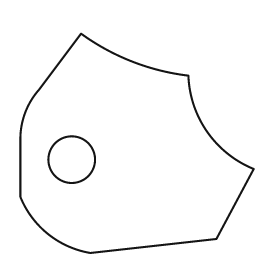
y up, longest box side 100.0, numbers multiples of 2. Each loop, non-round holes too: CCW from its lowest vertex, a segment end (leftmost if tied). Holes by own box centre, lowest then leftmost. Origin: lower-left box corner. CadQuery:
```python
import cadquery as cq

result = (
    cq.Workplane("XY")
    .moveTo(30.0, 0.0)
    .lineTo(84.0, 6.0)
    .lineTo(100.0, 36.0)
    .threePointArc((80.0, 52.0), (72.0, 76.0))
    .threePointArc((48.0, 82.0), (26.0, 94.0))
    .lineTo(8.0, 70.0)
    .threePointArc((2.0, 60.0), (0.0, 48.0))
    .lineTo(0.0, 24.0)
    .threePointArc((12.0, 8.0), (30.0, 0.0))
    .close()
    .moveTo(22.0, 40.0)
    .circle(10.0)
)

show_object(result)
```